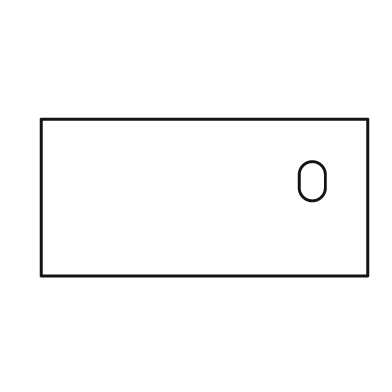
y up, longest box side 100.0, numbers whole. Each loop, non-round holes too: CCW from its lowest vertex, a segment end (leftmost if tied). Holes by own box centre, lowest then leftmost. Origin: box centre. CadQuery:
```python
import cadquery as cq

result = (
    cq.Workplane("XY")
    .moveTo(-50.0, -24.0)
    .lineTo(50.0, -24.0)
    .lineTo(50.0, 24.0)
    .lineTo(-50.0, 24.0)
    .close()
    .moveTo(29.0, 3.0)
    .threePointArc((33.0, -1.0), (37.0, 3.0))
    .lineTo(37.0, 7.0)
    .threePointArc((33.0, 11.0), (29.0, 7.0))
    .close()
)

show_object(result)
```